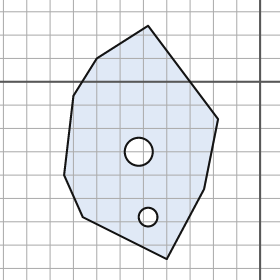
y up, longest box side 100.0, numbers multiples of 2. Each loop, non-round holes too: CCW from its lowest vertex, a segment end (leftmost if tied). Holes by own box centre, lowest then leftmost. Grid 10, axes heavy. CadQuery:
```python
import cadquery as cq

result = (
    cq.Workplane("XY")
    .moveTo(-40.0, -76.0)
    .lineTo(-24.0, -46.0)
    .lineTo(-18.0, -16.0)
    .lineTo(-48.0, 24.0)
    .lineTo(-70.0, 10.0)
    .lineTo(-80.0, -6.0)
    .lineTo(-84.0, -40.0)
    .lineTo(-76.0, -58.0)
    .close()
    .moveTo(-48.0, -58.0)
    .circle(4.0)
    .moveTo(-52.0, -30.0)
    .circle(6.0)
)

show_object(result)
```